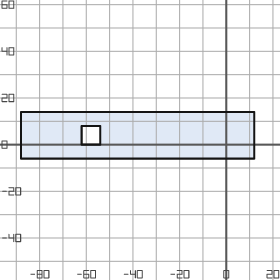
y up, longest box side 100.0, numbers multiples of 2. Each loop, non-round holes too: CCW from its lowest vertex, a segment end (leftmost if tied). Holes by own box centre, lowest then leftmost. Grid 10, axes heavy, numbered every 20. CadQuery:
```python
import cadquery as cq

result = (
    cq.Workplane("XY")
    .moveTo(-88.0, -6.0)
    .lineTo(12.0, -6.0)
    .lineTo(12.0, 14.0)
    .lineTo(-88.0, 14.0)
    .close()
    .moveTo(-62.0, 0.0)
    .lineTo(-54.0, 0.0)
    .lineTo(-54.0, 8.0)
    .lineTo(-62.0, 8.0)
    .close()
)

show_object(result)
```